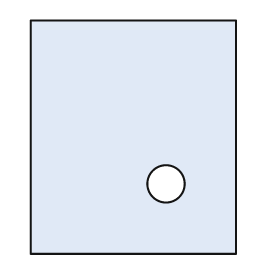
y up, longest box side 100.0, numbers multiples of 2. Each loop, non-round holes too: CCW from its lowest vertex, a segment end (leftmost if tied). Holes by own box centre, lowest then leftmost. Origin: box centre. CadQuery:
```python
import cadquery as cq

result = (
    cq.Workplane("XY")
    .moveTo(-44.0, -50.0)
    .lineTo(44.0, -50.0)
    .lineTo(44.0, 50.0)
    .lineTo(-44.0, 50.0)
    .close()
    .moveTo(14.0, -20.0)
    .circle(8.0)
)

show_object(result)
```